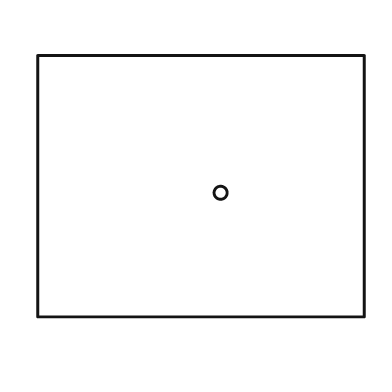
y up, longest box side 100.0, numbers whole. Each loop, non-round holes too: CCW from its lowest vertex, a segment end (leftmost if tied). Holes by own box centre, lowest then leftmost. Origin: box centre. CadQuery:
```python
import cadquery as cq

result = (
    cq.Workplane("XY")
    .moveTo(-50.0, -40.0)
    .lineTo(50.0, -40.0)
    .lineTo(50.0, 40.0)
    .lineTo(-50.0, 40.0)
    .close()
    .moveTo(6.0, -2.0)
    .circle(2.0)
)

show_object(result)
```